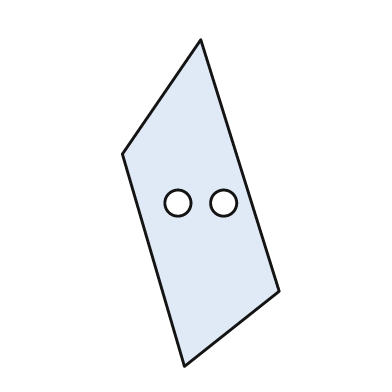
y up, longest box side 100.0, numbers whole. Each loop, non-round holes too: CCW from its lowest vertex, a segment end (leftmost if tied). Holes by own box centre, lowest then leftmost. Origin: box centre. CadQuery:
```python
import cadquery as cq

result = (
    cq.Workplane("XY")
    .moveTo(-5.0, -50.0)
    .lineTo(24.0, -27.0)
    .lineTo(0.0, 50.0)
    .lineTo(-24.0, 15.0)
    .close()
    .moveTo(-7.0, 0.0)
    .circle(4.0)
    .moveTo(7.0, 0.0)
    .circle(4.0)
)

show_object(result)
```